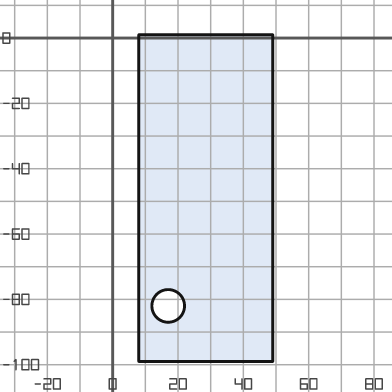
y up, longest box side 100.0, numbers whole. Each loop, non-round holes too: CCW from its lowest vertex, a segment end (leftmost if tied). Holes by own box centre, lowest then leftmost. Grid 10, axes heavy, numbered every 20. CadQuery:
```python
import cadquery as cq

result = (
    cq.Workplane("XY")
    .moveTo(8.0, -99.0)
    .lineTo(49.0, -99.0)
    .lineTo(49.0, 1.0)
    .lineTo(8.0, 1.0)
    .close()
    .moveTo(17.0, -82.0)
    .circle(5.0)
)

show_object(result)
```